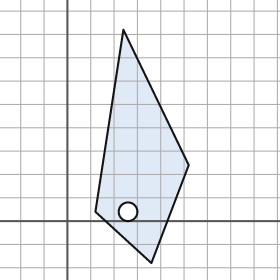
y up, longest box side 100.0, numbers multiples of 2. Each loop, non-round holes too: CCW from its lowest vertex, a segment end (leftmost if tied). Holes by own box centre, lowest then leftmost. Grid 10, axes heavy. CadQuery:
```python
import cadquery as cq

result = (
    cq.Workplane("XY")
    .moveTo(36.0, -18.0)
    .lineTo(52.0, 24.0)
    .lineTo(24.0, 82.0)
    .lineTo(12.0, 4.0)
    .close()
    .moveTo(26.0, 4.0)
    .circle(4.0)
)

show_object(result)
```